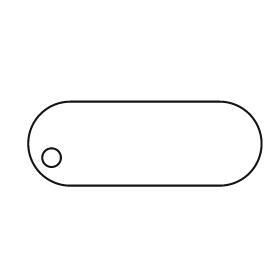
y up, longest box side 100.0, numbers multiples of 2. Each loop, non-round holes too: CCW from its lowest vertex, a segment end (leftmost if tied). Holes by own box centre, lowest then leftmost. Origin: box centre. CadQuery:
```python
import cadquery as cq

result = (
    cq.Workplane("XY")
    .moveTo(-32.0, -18.0)
    .lineTo(32.0, -18.0)
    .threePointArc((50.0, 0.0), (32.0, 18.0))
    .lineTo(-32.0, 18.0)
    .threePointArc((-50.0, 0.0), (-32.0, -18.0))
    .close()
    .moveTo(-40.0, -6.0)
    .circle(4.0)
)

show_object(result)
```